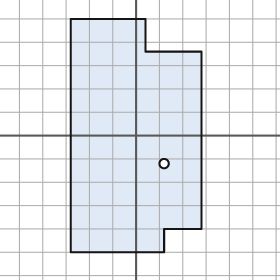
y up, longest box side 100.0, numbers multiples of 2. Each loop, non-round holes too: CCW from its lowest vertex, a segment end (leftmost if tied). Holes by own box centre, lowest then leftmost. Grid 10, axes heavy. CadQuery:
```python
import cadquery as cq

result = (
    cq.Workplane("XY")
    .moveTo(-28.0, -50.0)
    .lineTo(12.0, -50.0)
    .lineTo(12.0, -40.0)
    .lineTo(28.0, -40.0)
    .lineTo(28.0, 36.0)
    .lineTo(4.0, 36.0)
    .lineTo(4.0, 50.0)
    .lineTo(-28.0, 50.0)
    .close()
    .moveTo(12.0, -12.0)
    .circle(2.0)
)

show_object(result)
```